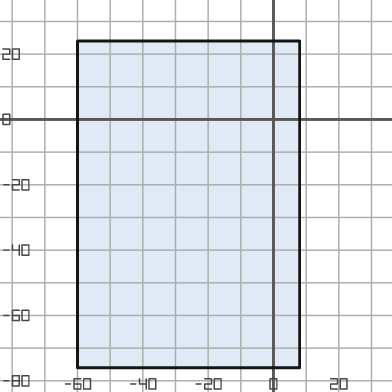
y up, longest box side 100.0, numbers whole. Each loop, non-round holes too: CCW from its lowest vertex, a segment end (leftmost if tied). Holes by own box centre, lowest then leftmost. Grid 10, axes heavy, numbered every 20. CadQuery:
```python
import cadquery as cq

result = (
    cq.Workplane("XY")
    .moveTo(-60.0, -76.0)
    .lineTo(8.0, -76.0)
    .lineTo(8.0, 24.0)
    .lineTo(-60.0, 24.0)
    .close()
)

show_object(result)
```